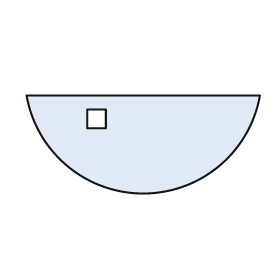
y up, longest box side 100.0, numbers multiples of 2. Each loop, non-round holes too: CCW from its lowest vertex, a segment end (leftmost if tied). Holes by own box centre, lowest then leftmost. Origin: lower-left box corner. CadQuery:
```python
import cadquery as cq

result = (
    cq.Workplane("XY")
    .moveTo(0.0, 42.0)
    .threePointArc((50.0, 0.0), (100.0, 42.0))
    .close()
    .moveTo(26.0, 28.0)
    .lineTo(34.0, 28.0)
    .lineTo(34.0, 36.0)
    .lineTo(26.0, 36.0)
    .close()
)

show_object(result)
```